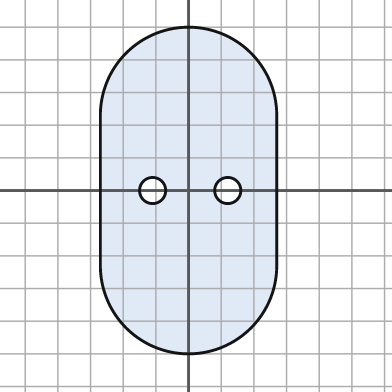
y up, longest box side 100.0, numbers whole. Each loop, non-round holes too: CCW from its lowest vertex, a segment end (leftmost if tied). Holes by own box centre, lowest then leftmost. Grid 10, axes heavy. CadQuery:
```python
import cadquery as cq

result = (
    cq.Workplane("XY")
    .moveTo(-27.0, -23.0)
    .threePointArc((0.0, -50.0), (27.0, -23.0))
    .lineTo(27.0, 23.0)
    .threePointArc((0.0, 50.0), (-27.0, 23.0))
    .close()
    .moveTo(-11.0, 0.0)
    .circle(4.0)
    .moveTo(12.0, 0.0)
    .circle(4.0)
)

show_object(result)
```